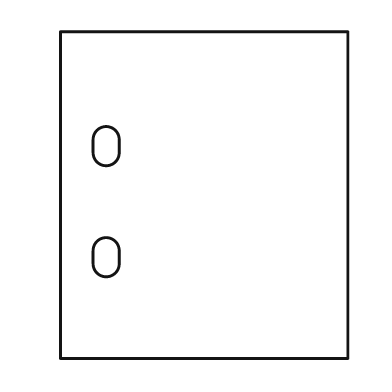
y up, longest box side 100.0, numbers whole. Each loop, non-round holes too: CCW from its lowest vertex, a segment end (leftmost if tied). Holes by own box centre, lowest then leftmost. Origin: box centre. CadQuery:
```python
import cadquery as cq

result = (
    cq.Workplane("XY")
    .moveTo(-44.0, -50.0)
    .lineTo(44.0, -50.0)
    .lineTo(44.0, 50.0)
    .lineTo(-44.0, 50.0)
    .close()
    .moveTo(-34.0, -21.0)
    .threePointArc((-30.0, -25.0), (-26.0, -21.0))
    .lineTo(-26.0, -17.0)
    .threePointArc((-30.0, -13.0), (-34.0, -17.0))
    .close()
    .moveTo(-34.0, 13.0)
    .threePointArc((-30.0, 9.0), (-26.0, 13.0))
    .lineTo(-26.0, 17.0)
    .threePointArc((-30.0, 21.0), (-34.0, 17.0))
    .close()
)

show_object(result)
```